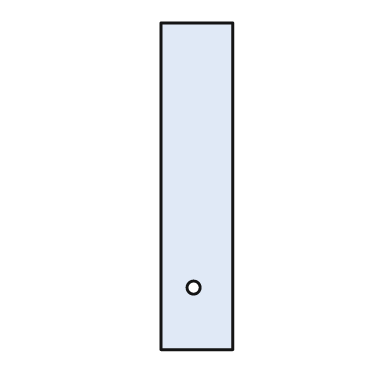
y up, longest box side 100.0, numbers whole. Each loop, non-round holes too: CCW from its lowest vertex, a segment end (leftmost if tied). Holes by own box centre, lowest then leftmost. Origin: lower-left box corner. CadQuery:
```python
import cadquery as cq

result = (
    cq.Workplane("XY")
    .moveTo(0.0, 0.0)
    .lineTo(22.0, 0.0)
    .lineTo(22.0, 100.0)
    .lineTo(0.0, 100.0)
    .close()
    .moveTo(10.0, 19.0)
    .circle(2.0)
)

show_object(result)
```